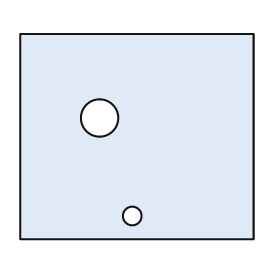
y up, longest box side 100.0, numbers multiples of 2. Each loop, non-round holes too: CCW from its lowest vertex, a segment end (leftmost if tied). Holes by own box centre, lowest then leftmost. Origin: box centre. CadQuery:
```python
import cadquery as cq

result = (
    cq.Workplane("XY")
    .moveTo(-50.0, -44.0)
    .lineTo(50.0, -44.0)
    .lineTo(50.0, 44.0)
    .lineTo(-50.0, 44.0)
    .close()
    .moveTo(-2.0, -34.0)
    .circle(4.0)
    .moveTo(-16.0, 8.0)
    .circle(8.0)
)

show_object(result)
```